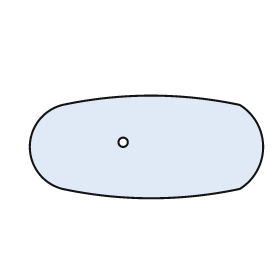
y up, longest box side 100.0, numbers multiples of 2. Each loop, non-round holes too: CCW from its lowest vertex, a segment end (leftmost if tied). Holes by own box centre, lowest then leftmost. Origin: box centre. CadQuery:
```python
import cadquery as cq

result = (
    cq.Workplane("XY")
    .moveTo(-36.0, -18.0)
    .threePointArc((2.0, -22.0), (40.0, -18.0))
    .threePointArc((50.0, 0.0), (40.0, 18.0))
    .threePointArc((2.0, 22.0), (-36.0, 18.0))
    .threePointArc((-50.0, 0.0), (-36.0, -18.0))
    .close()
    .moveTo(-10.0, 2.0)
    .circle(2.0)
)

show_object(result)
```